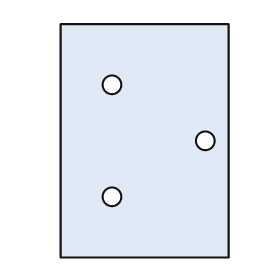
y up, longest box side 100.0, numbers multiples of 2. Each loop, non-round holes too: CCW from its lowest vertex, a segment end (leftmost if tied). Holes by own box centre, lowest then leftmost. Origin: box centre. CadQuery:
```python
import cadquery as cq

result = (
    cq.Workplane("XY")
    .moveTo(-36.0, -50.0)
    .lineTo(36.0, -50.0)
    .lineTo(36.0, 50.0)
    .lineTo(-36.0, 50.0)
    .close()
    .moveTo(-14.0, -24.0)
    .circle(4.0)
    .moveTo(26.0, 0.0)
    .circle(4.0)
    .moveTo(-14.0, 24.0)
    .circle(4.0)
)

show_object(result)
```